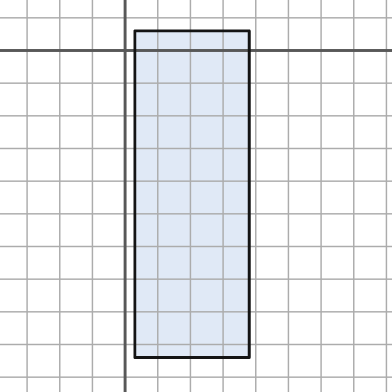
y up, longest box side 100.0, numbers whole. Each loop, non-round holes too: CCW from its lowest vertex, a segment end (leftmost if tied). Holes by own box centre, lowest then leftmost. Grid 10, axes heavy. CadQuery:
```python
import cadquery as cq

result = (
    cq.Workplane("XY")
    .moveTo(3.0, -94.0)
    .lineTo(38.0, -94.0)
    .lineTo(38.0, 6.0)
    .lineTo(3.0, 6.0)
    .close()
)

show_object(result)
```